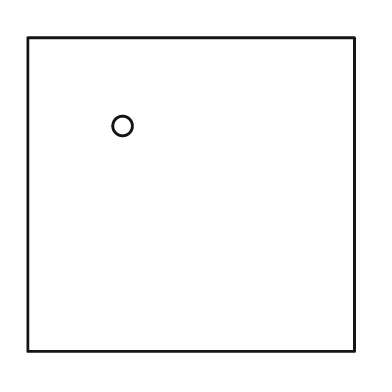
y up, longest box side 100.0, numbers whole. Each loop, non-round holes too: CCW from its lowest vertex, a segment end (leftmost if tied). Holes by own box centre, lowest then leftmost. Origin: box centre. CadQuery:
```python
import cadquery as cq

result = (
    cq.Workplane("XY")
    .moveTo(-50.0, -48.0)
    .lineTo(50.0, -48.0)
    .lineTo(50.0, 48.0)
    .lineTo(-50.0, 48.0)
    .close()
    .moveTo(-21.0, 21.0)
    .circle(3.0)
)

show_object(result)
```